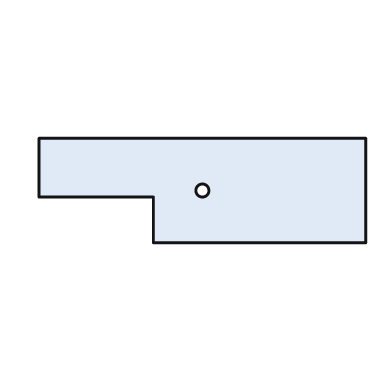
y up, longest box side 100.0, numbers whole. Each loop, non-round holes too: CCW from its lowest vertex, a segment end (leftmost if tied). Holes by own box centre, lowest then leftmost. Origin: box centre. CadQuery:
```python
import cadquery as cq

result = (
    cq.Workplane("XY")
    .moveTo(-15.0, -16.0)
    .lineTo(50.0, -16.0)
    .lineTo(50.0, 16.0)
    .lineTo(-50.0, 16.0)
    .lineTo(-50.0, -2.0)
    .lineTo(-15.0, -2.0)
    .close()
    .moveTo(0.0, 0.0)
    .circle(2.0)
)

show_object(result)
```